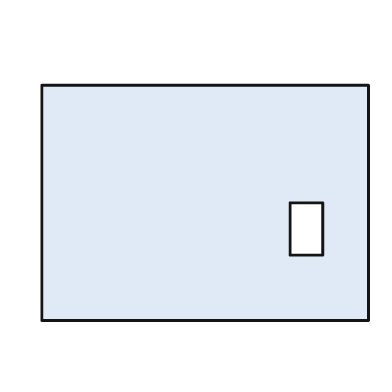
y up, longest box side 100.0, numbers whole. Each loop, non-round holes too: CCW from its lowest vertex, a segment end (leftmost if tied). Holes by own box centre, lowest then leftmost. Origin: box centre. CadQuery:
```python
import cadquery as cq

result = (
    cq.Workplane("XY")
    .moveTo(-50.0, -36.0)
    .lineTo(50.0, -36.0)
    .lineTo(50.0, 36.0)
    .lineTo(-50.0, 36.0)
    .close()
    .moveTo(26.0, -16.0)
    .lineTo(36.0, -16.0)
    .lineTo(36.0, 0.0)
    .lineTo(26.0, 0.0)
    .close()
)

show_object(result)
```